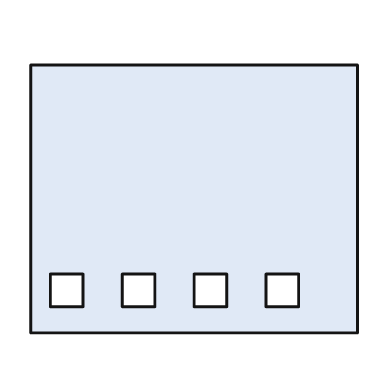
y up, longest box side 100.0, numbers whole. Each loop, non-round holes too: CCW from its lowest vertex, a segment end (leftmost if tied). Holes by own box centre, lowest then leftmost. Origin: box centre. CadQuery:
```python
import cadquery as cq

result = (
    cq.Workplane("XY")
    .moveTo(-50.0, -41.0)
    .lineTo(50.0, -41.0)
    .lineTo(50.0, 41.0)
    .lineTo(-50.0, 41.0)
    .close()
    .moveTo(-44.0, -33.0)
    .lineTo(-34.0, -33.0)
    .lineTo(-34.0, -23.0)
    .lineTo(-44.0, -23.0)
    .close()
    .moveTo(-22.0, -33.0)
    .lineTo(-12.0, -33.0)
    .lineTo(-12.0, -23.0)
    .lineTo(-22.0, -23.0)
    .close()
    .moveTo(0.0, -33.0)
    .lineTo(10.0, -33.0)
    .lineTo(10.0, -23.0)
    .lineTo(0.0, -23.0)
    .close()
    .moveTo(22.0, -33.0)
    .lineTo(32.0, -33.0)
    .lineTo(32.0, -23.0)
    .lineTo(22.0, -23.0)
    .close()
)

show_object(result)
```